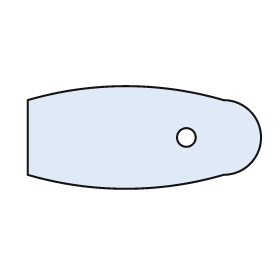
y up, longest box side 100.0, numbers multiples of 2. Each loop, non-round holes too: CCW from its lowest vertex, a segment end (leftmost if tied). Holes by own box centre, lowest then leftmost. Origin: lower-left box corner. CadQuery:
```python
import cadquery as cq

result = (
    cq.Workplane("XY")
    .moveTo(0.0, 6.0)
    .threePointArc((42.0, 0.0), (84.0, 6.0))
    .threePointArc((100.0, 22.0), (84.0, 38.0))
    .threePointArc((42.0, 44.0), (0.0, 38.0))
    .close()
    .moveTo(68.0, 22.0)
    .circle(4.0)
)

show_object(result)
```